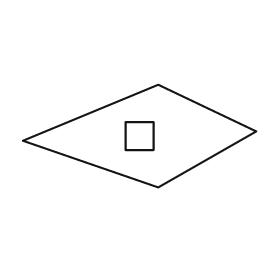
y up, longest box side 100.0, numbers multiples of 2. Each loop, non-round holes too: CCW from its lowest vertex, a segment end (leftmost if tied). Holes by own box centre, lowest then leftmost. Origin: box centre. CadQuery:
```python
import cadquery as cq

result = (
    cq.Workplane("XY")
    .moveTo(8.0, -22.0)
    .lineTo(50.0, 2.0)
    .lineTo(8.0, 22.0)
    .lineTo(-50.0, -2.0)
    .close()
    .moveTo(-6.0, -6.0)
    .lineTo(6.0, -6.0)
    .lineTo(6.0, 6.0)
    .lineTo(-6.0, 6.0)
    .close()
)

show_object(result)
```